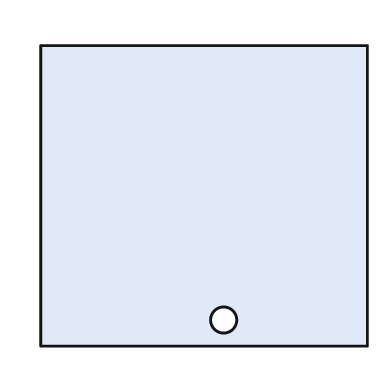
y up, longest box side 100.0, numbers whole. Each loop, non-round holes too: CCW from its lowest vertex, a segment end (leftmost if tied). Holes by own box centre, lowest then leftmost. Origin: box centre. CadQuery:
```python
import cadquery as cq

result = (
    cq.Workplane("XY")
    .moveTo(-50.0, -46.0)
    .lineTo(50.0, -46.0)
    .lineTo(50.0, 46.0)
    .lineTo(-50.0, 46.0)
    .close()
    .moveTo(6.0, -38.0)
    .circle(4.0)
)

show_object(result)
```